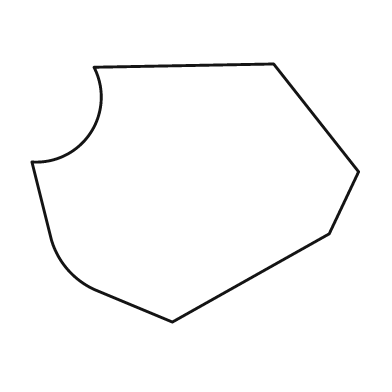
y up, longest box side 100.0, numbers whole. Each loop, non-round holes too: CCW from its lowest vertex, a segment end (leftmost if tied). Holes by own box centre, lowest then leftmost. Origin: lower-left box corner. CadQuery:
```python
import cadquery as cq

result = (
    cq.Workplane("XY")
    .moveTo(43.0, 0.0)
    .lineTo(91.0, 27.0)
    .lineTo(100.0, 46.0)
    .lineTo(74.0, 79.0)
    .lineTo(19.0, 78.0)
    .threePointArc((18.0, 58.0), (0.0, 49.0))
    .lineTo(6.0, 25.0)
    .threePointArc((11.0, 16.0), (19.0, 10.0))
    .close()
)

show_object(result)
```